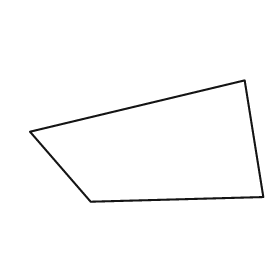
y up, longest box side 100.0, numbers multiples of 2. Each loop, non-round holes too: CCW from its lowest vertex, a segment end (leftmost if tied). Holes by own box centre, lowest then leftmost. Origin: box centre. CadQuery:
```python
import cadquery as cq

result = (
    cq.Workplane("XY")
    .moveTo(-24.0, -26.0)
    .lineTo(50.0, -24.0)
    .lineTo(42.0, 26.0)
    .lineTo(-50.0, 4.0)
    .close()
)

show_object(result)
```